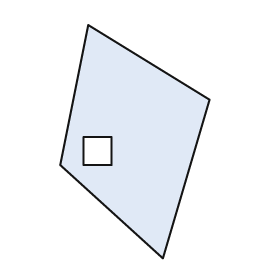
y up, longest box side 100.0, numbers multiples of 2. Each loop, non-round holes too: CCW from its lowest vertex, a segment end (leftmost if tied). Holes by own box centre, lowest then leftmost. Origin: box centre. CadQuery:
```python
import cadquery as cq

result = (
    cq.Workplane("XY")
    .moveTo(12.0, -50.0)
    .lineTo(32.0, 18.0)
    .lineTo(-20.0, 50.0)
    .lineTo(-32.0, -10.0)
    .close()
    .moveTo(-22.0, -10.0)
    .lineTo(-10.0, -10.0)
    .lineTo(-10.0, 2.0)
    .lineTo(-22.0, 2.0)
    .close()
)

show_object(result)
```